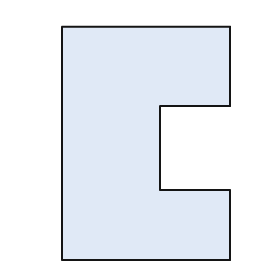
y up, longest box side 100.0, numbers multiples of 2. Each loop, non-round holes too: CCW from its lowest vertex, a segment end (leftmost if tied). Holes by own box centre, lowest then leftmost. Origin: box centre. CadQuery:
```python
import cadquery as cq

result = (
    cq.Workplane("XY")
    .moveTo(-36.0, -50.0)
    .lineTo(36.0, -50.0)
    .lineTo(36.0, -20.0)
    .lineTo(6.0, -20.0)
    .lineTo(6.0, 16.0)
    .lineTo(36.0, 16.0)
    .lineTo(36.0, 50.0)
    .lineTo(-36.0, 50.0)
    .close()
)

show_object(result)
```